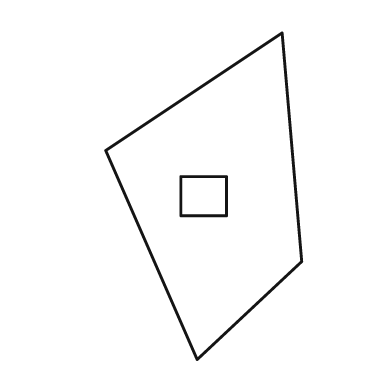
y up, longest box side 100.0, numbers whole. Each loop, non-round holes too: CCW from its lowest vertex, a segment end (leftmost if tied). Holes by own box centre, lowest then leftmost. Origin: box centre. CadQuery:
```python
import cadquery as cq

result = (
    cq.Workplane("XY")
    .moveTo(-2.0, -50.0)
    .lineTo(30.0, -20.0)
    .lineTo(24.0, 50.0)
    .lineTo(-30.0, 14.0)
    .close()
    .moveTo(-7.0, -6.0)
    .lineTo(7.0, -6.0)
    .lineTo(7.0, 6.0)
    .lineTo(-7.0, 6.0)
    .close()
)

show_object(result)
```